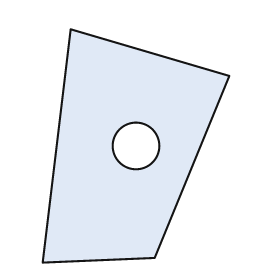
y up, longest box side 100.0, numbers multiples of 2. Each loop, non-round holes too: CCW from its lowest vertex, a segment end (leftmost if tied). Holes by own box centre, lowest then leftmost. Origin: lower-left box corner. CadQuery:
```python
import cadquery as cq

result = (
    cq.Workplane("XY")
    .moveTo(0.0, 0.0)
    .lineTo(48.0, 2.0)
    .lineTo(80.0, 80.0)
    .lineTo(12.0, 100.0)
    .close()
    .moveTo(40.0, 50.0)
    .circle(10.0)
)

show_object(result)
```